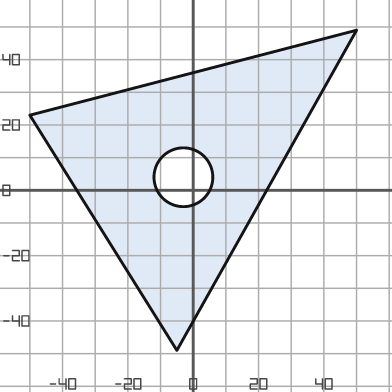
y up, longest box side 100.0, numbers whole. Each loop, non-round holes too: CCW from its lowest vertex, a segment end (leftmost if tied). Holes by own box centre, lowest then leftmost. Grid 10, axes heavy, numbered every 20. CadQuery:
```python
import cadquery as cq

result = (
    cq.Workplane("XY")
    .moveTo(-5.0, -49.0)
    .lineTo(50.0, 49.0)
    .lineTo(-50.0, 23.0)
    .close()
    .moveTo(-3.0, 4.0)
    .circle(9.0)
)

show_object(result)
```